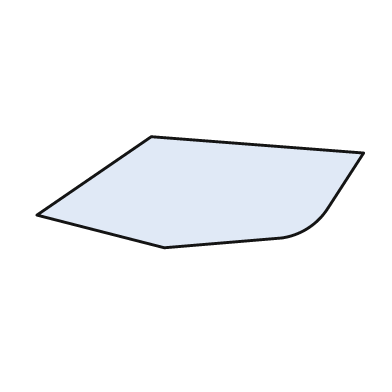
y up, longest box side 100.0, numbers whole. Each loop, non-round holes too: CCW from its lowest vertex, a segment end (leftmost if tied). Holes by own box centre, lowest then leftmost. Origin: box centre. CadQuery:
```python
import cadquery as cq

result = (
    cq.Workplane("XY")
    .moveTo(-11.0, -17.0)
    .lineTo(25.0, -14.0)
    .threePointArc((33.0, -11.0), (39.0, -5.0))
    .lineTo(50.0, 12.0)
    .lineTo(-15.0, 17.0)
    .lineTo(-50.0, -7.0)
    .close()
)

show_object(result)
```